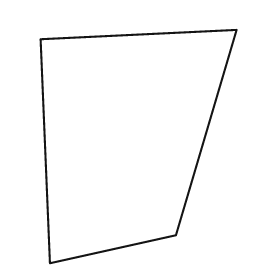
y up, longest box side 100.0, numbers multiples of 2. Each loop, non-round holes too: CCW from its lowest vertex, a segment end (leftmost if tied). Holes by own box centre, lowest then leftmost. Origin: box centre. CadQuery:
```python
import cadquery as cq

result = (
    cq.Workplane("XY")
    .moveTo(-38.0, -50.0)
    .lineTo(16.0, -38.0)
    .lineTo(42.0, 50.0)
    .lineTo(-42.0, 46.0)
    .close()
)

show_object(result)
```